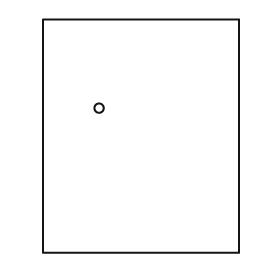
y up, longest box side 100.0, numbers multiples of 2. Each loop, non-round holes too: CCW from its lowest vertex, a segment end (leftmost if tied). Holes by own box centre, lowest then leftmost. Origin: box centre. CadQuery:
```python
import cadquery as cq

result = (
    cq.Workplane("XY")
    .moveTo(-42.0, -50.0)
    .lineTo(42.0, -50.0)
    .lineTo(42.0, 50.0)
    .lineTo(-42.0, 50.0)
    .close()
    .moveTo(-18.0, 12.0)
    .circle(2.0)
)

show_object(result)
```